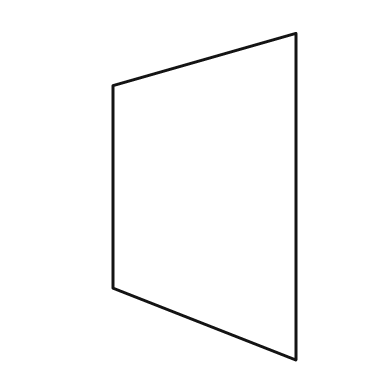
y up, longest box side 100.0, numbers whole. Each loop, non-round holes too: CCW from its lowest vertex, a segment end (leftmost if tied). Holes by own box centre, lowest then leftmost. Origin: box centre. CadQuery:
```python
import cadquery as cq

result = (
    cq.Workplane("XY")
    .moveTo(28.0, -50.0)
    .lineTo(28.0, 50.0)
    .lineTo(-28.0, 34.0)
    .lineTo(-28.0, -28.0)
    .close()
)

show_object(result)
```